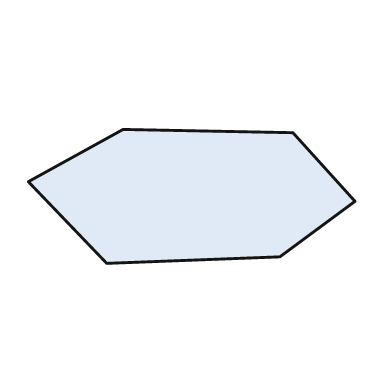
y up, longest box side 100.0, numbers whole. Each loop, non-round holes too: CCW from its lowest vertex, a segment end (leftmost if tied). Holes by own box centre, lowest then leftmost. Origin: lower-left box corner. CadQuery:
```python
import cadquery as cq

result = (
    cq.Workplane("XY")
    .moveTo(24.0, 0.0)
    .lineTo(77.0, 2.0)
    .lineTo(100.0, 19.0)
    .lineTo(81.0, 40.0)
    .lineTo(29.0, 41.0)
    .lineTo(0.0, 25.0)
    .close()
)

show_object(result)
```